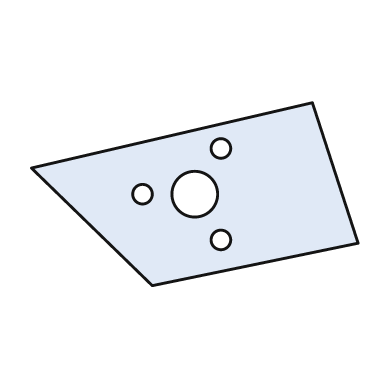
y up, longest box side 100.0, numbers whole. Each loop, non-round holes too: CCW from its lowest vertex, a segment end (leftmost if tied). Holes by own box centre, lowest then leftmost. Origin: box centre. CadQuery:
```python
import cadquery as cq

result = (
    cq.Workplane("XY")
    .moveTo(-13.0, -28.0)
    .lineTo(50.0, -15.0)
    .lineTo(36.0, 28.0)
    .lineTo(-50.0, 8.0)
    .close()
    .moveTo(8.0, -14.0)
    .circle(3.0)
    .moveTo(-16.0, 0.0)
    .circle(3.0)
    .moveTo(0.0, 0.0)
    .circle(7.0)
    .moveTo(8.0, 14.0)
    .circle(3.0)
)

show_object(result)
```